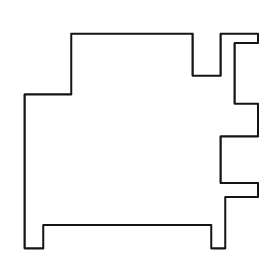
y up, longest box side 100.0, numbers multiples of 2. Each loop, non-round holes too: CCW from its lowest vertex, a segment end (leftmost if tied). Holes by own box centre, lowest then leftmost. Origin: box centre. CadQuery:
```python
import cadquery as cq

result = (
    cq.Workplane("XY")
    .moveTo(-50.0, -46.0)
    .lineTo(-42.0, -46.0)
    .lineTo(-42.0, -36.0)
    .lineTo(30.0, -36.0)
    .lineTo(30.0, -46.0)
    .lineTo(36.0, -46.0)
    .lineTo(36.0, -24.0)
    .lineTo(50.0, -24.0)
    .lineTo(50.0, -18.0)
    .lineTo(34.0, -18.0)
    .lineTo(34.0, 2.0)
    .lineTo(50.0, 2.0)
    .lineTo(50.0, 16.0)
    .lineTo(40.0, 16.0)
    .lineTo(40.0, 42.0)
    .lineTo(50.0, 42.0)
    .lineTo(50.0, 46.0)
    .lineTo(34.0, 46.0)
    .lineTo(34.0, 28.0)
    .lineTo(22.0, 28.0)
    .lineTo(22.0, 46.0)
    .lineTo(-30.0, 46.0)
    .lineTo(-30.0, 20.0)
    .lineTo(-50.0, 20.0)
    .close()
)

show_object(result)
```